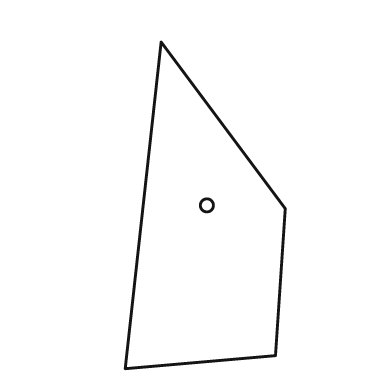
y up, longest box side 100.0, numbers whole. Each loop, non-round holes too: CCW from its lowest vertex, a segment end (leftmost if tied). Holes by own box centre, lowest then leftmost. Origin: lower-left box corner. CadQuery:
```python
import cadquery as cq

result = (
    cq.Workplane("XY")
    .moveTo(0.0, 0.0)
    .lineTo(46.0, 4.0)
    .lineTo(49.0, 49.0)
    .lineTo(11.0, 100.0)
    .close()
    .moveTo(25.0, 50.0)
    .circle(2.0)
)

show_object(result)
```